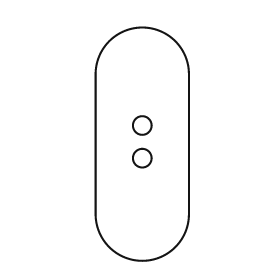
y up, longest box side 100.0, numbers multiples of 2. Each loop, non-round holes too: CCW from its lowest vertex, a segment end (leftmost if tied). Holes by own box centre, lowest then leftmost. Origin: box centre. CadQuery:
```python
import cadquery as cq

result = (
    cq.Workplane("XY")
    .moveTo(-20.0, -30.0)
    .threePointArc((0.0, -50.0), (20.0, -30.0))
    .lineTo(20.0, 30.0)
    .threePointArc((0.0, 50.0), (-20.0, 30.0))
    .close()
    .moveTo(0.0, -6.0)
    .circle(4.0)
    .moveTo(0.0, 8.0)
    .circle(4.0)
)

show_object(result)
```